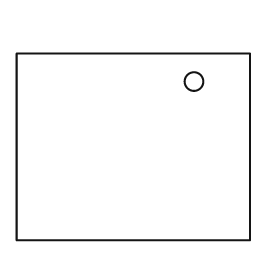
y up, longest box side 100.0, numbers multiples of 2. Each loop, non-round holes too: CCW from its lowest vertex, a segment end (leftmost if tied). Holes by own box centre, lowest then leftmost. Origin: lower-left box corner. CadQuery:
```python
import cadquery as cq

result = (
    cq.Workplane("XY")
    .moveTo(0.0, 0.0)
    .lineTo(100.0, 0.0)
    .lineTo(100.0, 80.0)
    .lineTo(0.0, 80.0)
    .close()
    .moveTo(76.0, 68.0)
    .circle(4.0)
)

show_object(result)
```